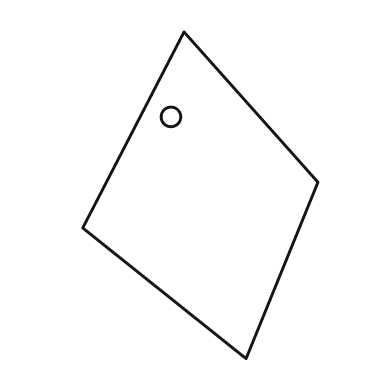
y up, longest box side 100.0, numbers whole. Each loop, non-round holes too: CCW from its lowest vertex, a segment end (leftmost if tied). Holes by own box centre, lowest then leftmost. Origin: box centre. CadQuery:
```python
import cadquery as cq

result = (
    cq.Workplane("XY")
    .moveTo(14.0, -50.0)
    .lineTo(36.0, 4.0)
    .lineTo(-5.0, 50.0)
    .lineTo(-36.0, -10.0)
    .close()
    .moveTo(-9.0, 24.0)
    .circle(3.0)
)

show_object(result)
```